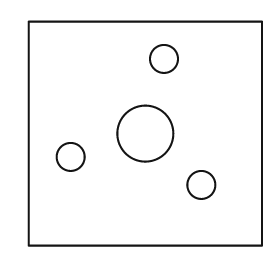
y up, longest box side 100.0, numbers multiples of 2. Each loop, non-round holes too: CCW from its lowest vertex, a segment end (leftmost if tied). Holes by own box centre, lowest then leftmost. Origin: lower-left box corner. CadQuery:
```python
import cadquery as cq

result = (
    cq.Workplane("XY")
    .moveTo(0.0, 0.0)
    .lineTo(100.0, 0.0)
    .lineTo(100.0, 96.0)
    .lineTo(0.0, 96.0)
    .close()
    .moveTo(74.0, 26.0)
    .circle(6.0)
    .moveTo(18.0, 38.0)
    .circle(6.0)
    .moveTo(50.0, 48.0)
    .circle(12.0)
    .moveTo(58.0, 80.0)
    .circle(6.0)
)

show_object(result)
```